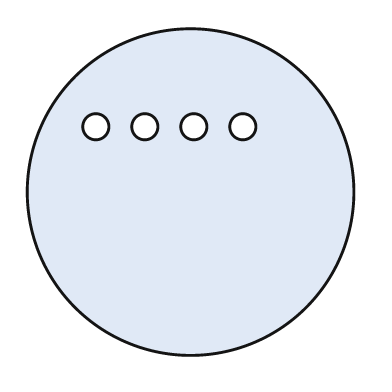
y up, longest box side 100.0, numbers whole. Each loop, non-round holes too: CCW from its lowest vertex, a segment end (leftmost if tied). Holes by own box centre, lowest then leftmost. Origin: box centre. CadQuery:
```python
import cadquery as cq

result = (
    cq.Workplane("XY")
    .moveTo(0.0, 0.0)
    .circle(50.0)
    .moveTo(-29.0, 20.0)
    .circle(4.0)
    .moveTo(-14.0, 20.0)
    .circle(4.0)
    .moveTo(1.0, 20.0)
    .circle(4.0)
    .moveTo(16.0, 20.0)
    .circle(4.0)
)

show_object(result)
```